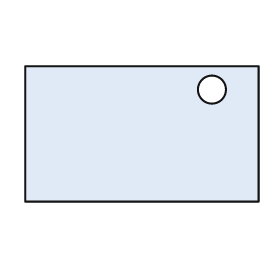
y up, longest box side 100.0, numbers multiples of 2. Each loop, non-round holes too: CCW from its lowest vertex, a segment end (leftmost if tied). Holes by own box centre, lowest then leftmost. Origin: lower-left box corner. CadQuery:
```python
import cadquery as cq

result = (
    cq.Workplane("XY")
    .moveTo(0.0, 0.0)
    .lineTo(100.0, 0.0)
    .lineTo(100.0, 58.0)
    .lineTo(0.0, 58.0)
    .close()
    .moveTo(80.0, 48.0)
    .circle(6.0)
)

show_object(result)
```